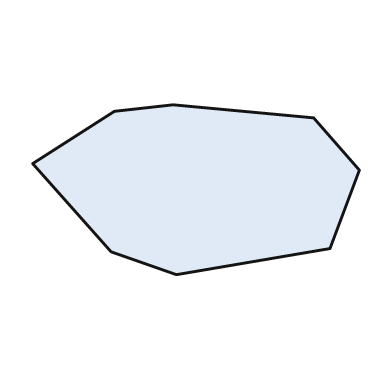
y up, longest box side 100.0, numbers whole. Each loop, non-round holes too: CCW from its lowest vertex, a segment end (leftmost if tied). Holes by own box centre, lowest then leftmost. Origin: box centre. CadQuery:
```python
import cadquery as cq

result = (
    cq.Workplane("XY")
    .moveTo(-6.0, -26.0)
    .lineTo(41.0, -18.0)
    .lineTo(50.0, 6.0)
    .lineTo(36.0, 22.0)
    .lineTo(-7.0, 26.0)
    .lineTo(-25.0, 24.0)
    .lineTo(-50.0, 8.0)
    .lineTo(-26.0, -19.0)
    .close()
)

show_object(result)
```